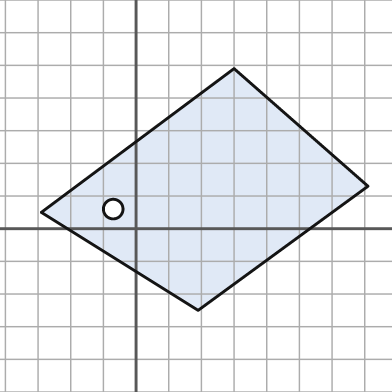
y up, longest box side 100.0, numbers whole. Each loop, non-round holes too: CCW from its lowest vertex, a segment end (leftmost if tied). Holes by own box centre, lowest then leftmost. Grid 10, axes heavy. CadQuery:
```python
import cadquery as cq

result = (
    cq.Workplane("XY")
    .moveTo(19.0, -25.0)
    .lineTo(71.0, 13.0)
    .lineTo(30.0, 49.0)
    .lineTo(-29.0, 5.0)
    .close()
    .moveTo(-7.0, 6.0)
    .circle(3.0)
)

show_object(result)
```